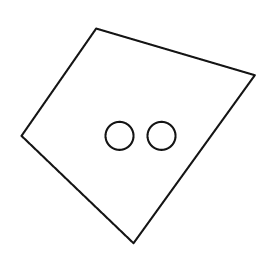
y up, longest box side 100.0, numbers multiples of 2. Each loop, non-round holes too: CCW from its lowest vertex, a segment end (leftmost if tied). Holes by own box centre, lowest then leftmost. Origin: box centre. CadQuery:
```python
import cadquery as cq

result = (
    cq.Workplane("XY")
    .moveTo(-2.0, -46.0)
    .lineTo(50.0, 26.0)
    .lineTo(-18.0, 46.0)
    .lineTo(-50.0, 0.0)
    .close()
    .moveTo(-8.0, 0.0)
    .circle(6.0)
    .moveTo(10.0, 0.0)
    .circle(6.0)
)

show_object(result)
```